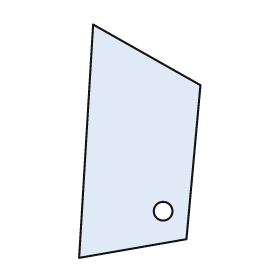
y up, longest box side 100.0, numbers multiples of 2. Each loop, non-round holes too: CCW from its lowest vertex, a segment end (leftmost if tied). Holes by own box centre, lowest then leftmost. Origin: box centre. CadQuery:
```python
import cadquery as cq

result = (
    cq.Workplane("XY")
    .moveTo(-26.0, -50.0)
    .lineTo(20.0, -42.0)
    .lineTo(26.0, 24.0)
    .lineTo(-20.0, 50.0)
    .close()
    .moveTo(10.0, -30.0)
    .circle(4.0)
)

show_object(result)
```